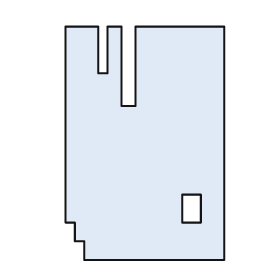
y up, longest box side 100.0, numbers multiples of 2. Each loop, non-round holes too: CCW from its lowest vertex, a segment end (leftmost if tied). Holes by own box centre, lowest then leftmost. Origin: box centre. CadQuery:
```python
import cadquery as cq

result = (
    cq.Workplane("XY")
    .moveTo(-26.0, -50.0)
    .lineTo(34.0, -50.0)
    .lineTo(34.0, 50.0)
    .lineTo(-4.0, 50.0)
    .lineTo(-4.0, 16.0)
    .lineTo(-10.0, 16.0)
    .lineTo(-10.0, 50.0)
    .lineTo(-16.0, 50.0)
    .lineTo(-16.0, 30.0)
    .lineTo(-20.0, 30.0)
    .lineTo(-20.0, 50.0)
    .lineTo(-34.0, 50.0)
    .lineTo(-34.0, -34.0)
    .lineTo(-30.0, -34.0)
    .lineTo(-30.0, -42.0)
    .lineTo(-26.0, -42.0)
    .close()
    .moveTo(16.0, -34.0)
    .lineTo(24.0, -34.0)
    .lineTo(24.0, -22.0)
    .lineTo(16.0, -22.0)
    .close()
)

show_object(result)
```